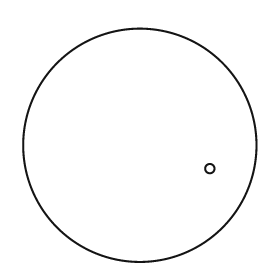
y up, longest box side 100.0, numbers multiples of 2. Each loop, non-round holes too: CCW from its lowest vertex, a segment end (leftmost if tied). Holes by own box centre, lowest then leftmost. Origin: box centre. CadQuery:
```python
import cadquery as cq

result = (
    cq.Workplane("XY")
    .moveTo(0.0, 0.0)
    .circle(50.0)
    .moveTo(30.0, -10.0)
    .circle(2.0)
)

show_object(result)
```